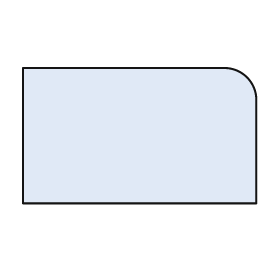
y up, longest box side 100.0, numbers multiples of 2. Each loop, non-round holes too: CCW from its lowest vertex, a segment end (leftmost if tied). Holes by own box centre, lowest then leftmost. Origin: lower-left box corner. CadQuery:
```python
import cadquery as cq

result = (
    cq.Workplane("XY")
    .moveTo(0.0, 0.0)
    .lineTo(100.0, 0.0)
    .lineTo(100.0, 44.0)
    .threePointArc((96.0, 54.0), (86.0, 58.0))
    .lineTo(0.0, 58.0)
    .close()
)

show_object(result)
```